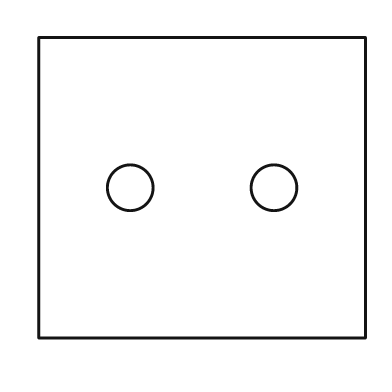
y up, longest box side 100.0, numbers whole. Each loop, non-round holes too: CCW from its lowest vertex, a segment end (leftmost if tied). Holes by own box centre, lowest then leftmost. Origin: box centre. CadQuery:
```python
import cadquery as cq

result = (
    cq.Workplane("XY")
    .moveTo(-50.0, -46.0)
    .lineTo(50.0, -46.0)
    .lineTo(50.0, 46.0)
    .lineTo(-50.0, 46.0)
    .close()
    .moveTo(-22.0, 0.0)
    .circle(7.0)
    .moveTo(22.0, 0.0)
    .circle(7.0)
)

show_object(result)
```